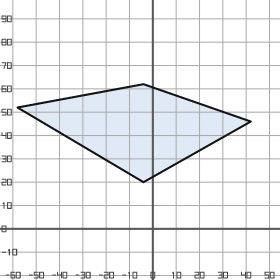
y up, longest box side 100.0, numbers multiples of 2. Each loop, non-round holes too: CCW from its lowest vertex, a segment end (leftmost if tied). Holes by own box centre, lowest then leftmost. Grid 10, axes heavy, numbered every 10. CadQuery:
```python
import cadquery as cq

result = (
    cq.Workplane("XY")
    .moveTo(-4.0, 20.0)
    .lineTo(42.0, 46.0)
    .lineTo(-4.0, 62.0)
    .lineTo(-58.0, 52.0)
    .close()
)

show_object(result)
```